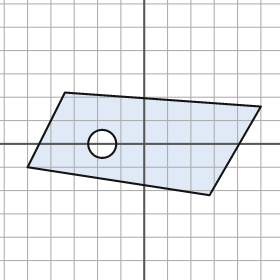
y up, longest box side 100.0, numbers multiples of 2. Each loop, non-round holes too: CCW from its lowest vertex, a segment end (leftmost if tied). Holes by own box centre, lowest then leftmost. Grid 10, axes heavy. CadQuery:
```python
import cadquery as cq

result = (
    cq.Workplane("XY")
    .moveTo(28.0, -22.0)
    .lineTo(50.0, 16.0)
    .lineTo(-34.0, 22.0)
    .lineTo(-50.0, -10.0)
    .close()
    .moveTo(-18.0, 0.0)
    .circle(6.0)
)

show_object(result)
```